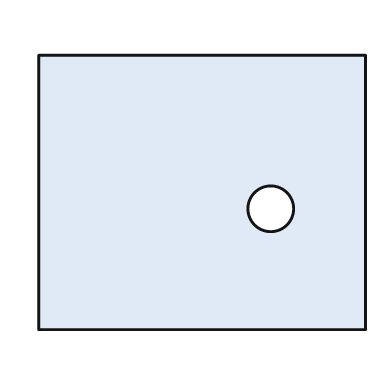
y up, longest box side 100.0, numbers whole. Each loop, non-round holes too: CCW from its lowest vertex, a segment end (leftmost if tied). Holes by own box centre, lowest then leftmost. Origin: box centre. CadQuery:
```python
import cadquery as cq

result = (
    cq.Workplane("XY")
    .moveTo(-50.0, -42.0)
    .lineTo(50.0, -42.0)
    .lineTo(50.0, 42.0)
    .lineTo(-50.0, 42.0)
    .close()
    .moveTo(21.0, -5.0)
    .circle(7.0)
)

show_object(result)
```